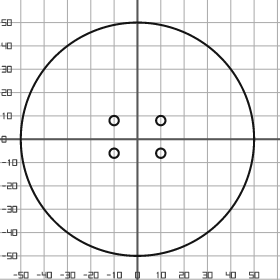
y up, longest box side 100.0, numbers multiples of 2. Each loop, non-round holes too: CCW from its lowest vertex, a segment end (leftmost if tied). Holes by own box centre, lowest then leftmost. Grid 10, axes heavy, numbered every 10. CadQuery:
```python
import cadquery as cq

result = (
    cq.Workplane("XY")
    .moveTo(0.0, 0.0)
    .circle(50.0)
    .moveTo(-10.0, -6.0)
    .circle(2.0)
    .moveTo(10.0, -6.0)
    .circle(2.0)
    .moveTo(-10.0, 8.0)
    .circle(2.0)
    .moveTo(10.0, 8.0)
    .circle(2.0)
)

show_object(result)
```